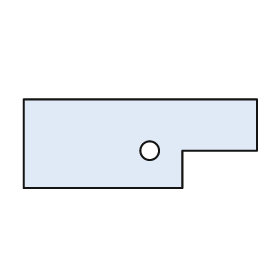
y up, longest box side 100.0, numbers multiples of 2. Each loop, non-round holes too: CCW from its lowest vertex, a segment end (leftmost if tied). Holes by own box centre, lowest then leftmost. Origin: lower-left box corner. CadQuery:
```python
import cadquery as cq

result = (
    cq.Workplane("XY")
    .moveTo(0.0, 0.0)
    .lineTo(68.0, 0.0)
    .lineTo(68.0, 16.0)
    .lineTo(100.0, 16.0)
    .lineTo(100.0, 38.0)
    .lineTo(0.0, 38.0)
    .close()
    .moveTo(54.0, 16.0)
    .circle(4.0)
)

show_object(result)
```